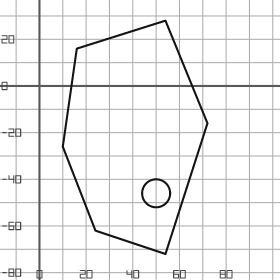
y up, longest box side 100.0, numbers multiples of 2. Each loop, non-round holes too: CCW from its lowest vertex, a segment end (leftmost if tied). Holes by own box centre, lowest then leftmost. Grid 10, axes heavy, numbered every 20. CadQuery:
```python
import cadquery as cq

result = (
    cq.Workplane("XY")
    .moveTo(54.0, -72.0)
    .lineTo(72.0, -16.0)
    .lineTo(54.0, 28.0)
    .lineTo(16.0, 16.0)
    .lineTo(10.0, -26.0)
    .lineTo(24.0, -62.0)
    .close()
    .moveTo(50.0, -46.0)
    .circle(6.0)
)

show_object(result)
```